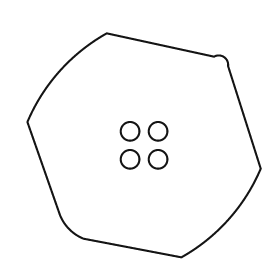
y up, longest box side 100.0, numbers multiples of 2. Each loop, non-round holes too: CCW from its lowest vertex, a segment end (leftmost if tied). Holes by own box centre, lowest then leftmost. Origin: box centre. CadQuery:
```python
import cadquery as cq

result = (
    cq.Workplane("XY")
    .moveTo(16.0, -48.0)
    .threePointArc((36.0, -32.0), (50.0, -10.0))
    .lineTo(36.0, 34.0)
    .threePointArc((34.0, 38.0), (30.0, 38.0))
    .lineTo(-16.0, 48.0)
    .threePointArc((-36.0, 32.0), (-50.0, 10.0))
    .lineTo(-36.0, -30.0)
    .threePointArc((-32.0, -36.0), (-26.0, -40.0))
    .close()
    .moveTo(-6.0, -6.0)
    .circle(4.0)
    .moveTo(6.0, -6.0)
    .circle(4.0)
    .moveTo(-6.0, 6.0)
    .circle(4.0)
    .moveTo(6.0, 6.0)
    .circle(4.0)
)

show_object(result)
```